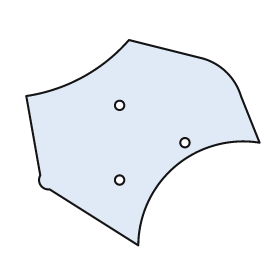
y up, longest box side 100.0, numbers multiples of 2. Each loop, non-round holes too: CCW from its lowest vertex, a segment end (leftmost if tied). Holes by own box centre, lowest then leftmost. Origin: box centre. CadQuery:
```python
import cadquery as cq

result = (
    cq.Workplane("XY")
    .moveTo(-2.0, -44.0)
    .threePointArc((14.0, -10.0), (50.0, 0.0))
    .lineTo(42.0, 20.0)
    .threePointArc((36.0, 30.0), (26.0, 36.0))
    .lineTo(-6.0, 44.0)
    .threePointArc((-26.0, 28.0), (-50.0, 20.0))
    .lineTo(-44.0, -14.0)
    .threePointArc((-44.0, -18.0), (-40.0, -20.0))
    .close()
    .moveTo(-10.0, -16.0)
    .circle(2.0)
    .moveTo(18.0, 0.0)
    .circle(2.0)
    .moveTo(-10.0, 16.0)
    .circle(2.0)
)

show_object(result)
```